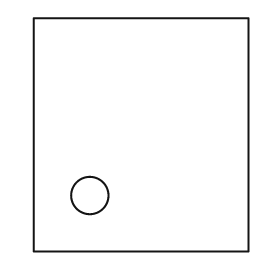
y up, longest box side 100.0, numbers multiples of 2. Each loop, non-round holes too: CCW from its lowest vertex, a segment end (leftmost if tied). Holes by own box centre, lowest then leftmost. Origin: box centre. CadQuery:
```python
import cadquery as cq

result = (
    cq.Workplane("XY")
    .moveTo(-46.0, -50.0)
    .lineTo(46.0, -50.0)
    .lineTo(46.0, 50.0)
    .lineTo(-46.0, 50.0)
    .close()
    .moveTo(-22.0, -26.0)
    .circle(8.0)
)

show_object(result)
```